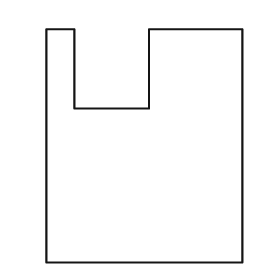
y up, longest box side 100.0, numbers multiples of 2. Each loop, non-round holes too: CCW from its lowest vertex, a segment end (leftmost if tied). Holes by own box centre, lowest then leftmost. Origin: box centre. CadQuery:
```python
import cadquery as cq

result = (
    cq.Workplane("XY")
    .moveTo(-42.0, -50.0)
    .lineTo(42.0, -50.0)
    .lineTo(42.0, 50.0)
    .lineTo(2.0, 50.0)
    .lineTo(2.0, 16.0)
    .lineTo(-30.0, 16.0)
    .lineTo(-30.0, 50.0)
    .lineTo(-42.0, 50.0)
    .close()
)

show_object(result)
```